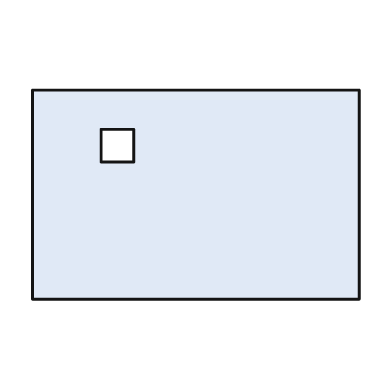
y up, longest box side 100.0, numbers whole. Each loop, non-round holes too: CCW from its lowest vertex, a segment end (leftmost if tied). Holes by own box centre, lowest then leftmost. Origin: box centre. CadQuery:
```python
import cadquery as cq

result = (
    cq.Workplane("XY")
    .moveTo(-50.0, -32.0)
    .lineTo(50.0, -32.0)
    .lineTo(50.0, 32.0)
    .lineTo(-50.0, 32.0)
    .close()
    .moveTo(-29.0, 10.0)
    .lineTo(-19.0, 10.0)
    .lineTo(-19.0, 20.0)
    .lineTo(-29.0, 20.0)
    .close()
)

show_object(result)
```